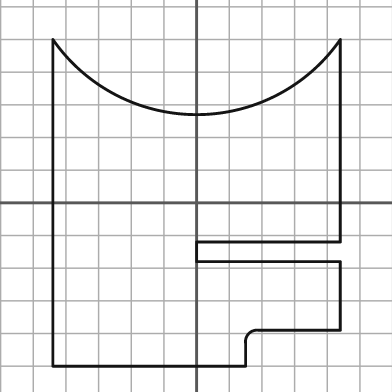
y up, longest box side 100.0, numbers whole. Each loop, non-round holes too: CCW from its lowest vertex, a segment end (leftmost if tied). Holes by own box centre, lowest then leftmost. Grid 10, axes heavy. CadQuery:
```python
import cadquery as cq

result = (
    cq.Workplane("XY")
    .moveTo(-44.0, -50.0)
    .lineTo(15.0, -50.0)
    .lineTo(15.0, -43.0)
    .threePointArc((16.0, -40.0), (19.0, -39.0))
    .lineTo(44.0, -39.0)
    .lineTo(44.0, -18.0)
    .lineTo(0.0, -18.0)
    .lineTo(0.0, -12.0)
    .lineTo(44.0, -12.0)
    .lineTo(44.0, 50.0)
    .threePointArc((0.0, 27.0), (-44.0, 50.0))
    .close()
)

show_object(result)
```